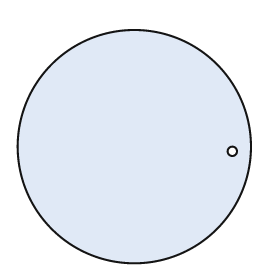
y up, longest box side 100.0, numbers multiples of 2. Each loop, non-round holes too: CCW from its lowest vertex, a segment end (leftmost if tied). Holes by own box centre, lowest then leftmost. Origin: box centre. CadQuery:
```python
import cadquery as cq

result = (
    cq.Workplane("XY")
    .moveTo(0.0, 0.0)
    .circle(50.0)
    .moveTo(42.0, -2.0)
    .circle(2.0)
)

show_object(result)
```